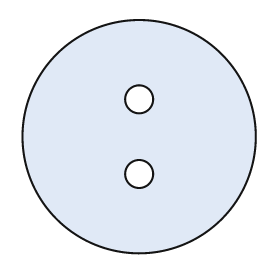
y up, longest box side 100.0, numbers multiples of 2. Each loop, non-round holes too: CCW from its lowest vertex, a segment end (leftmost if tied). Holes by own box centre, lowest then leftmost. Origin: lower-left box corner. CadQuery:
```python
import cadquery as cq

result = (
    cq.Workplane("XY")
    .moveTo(50.0, 50.0)
    .circle(50.0)
    .moveTo(50.0, 34.0)
    .circle(6.0)
    .moveTo(50.0, 66.0)
    .circle(6.0)
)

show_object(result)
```